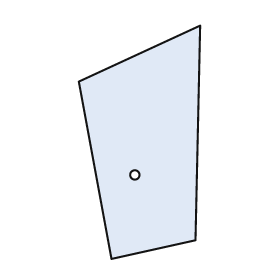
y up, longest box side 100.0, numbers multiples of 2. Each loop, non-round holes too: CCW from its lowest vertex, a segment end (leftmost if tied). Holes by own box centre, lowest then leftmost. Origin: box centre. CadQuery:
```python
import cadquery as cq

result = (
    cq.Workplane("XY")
    .moveTo(-12.0, -50.0)
    .lineTo(24.0, -42.0)
    .lineTo(26.0, 50.0)
    .lineTo(-26.0, 26.0)
    .close()
    .moveTo(-2.0, -14.0)
    .circle(2.0)
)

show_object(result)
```